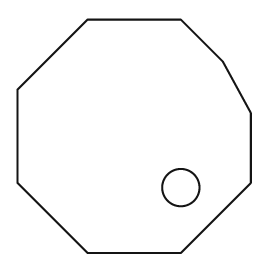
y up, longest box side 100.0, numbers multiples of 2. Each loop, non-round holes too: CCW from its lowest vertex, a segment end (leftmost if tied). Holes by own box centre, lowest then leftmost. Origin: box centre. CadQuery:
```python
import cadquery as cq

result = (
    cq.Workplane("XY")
    .moveTo(-20.0, -50.0)
    .lineTo(20.0, -50.0)
    .lineTo(50.0, -20.0)
    .lineTo(50.0, 10.0)
    .lineTo(38.0, 32.0)
    .lineTo(20.0, 50.0)
    .lineTo(-20.0, 50.0)
    .lineTo(-50.0, 20.0)
    .lineTo(-50.0, -20.0)
    .close()
    .moveTo(20.0, -22.0)
    .circle(8.0)
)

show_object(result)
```